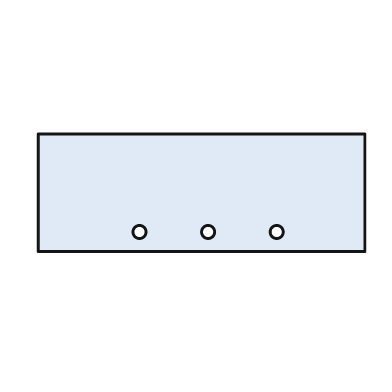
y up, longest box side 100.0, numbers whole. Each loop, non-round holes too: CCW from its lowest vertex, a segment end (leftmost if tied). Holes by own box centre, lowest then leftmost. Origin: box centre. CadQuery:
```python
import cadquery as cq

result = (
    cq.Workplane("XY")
    .moveTo(-50.0, -18.0)
    .lineTo(50.0, -18.0)
    .lineTo(50.0, 18.0)
    .lineTo(-50.0, 18.0)
    .close()
    .moveTo(-19.0, -12.0)
    .circle(2.0)
    .moveTo(2.0, -12.0)
    .circle(2.0)
    .moveTo(23.0, -12.0)
    .circle(2.0)
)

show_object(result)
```